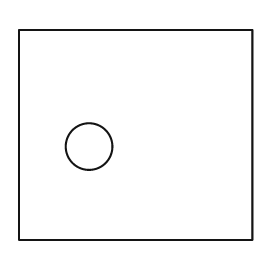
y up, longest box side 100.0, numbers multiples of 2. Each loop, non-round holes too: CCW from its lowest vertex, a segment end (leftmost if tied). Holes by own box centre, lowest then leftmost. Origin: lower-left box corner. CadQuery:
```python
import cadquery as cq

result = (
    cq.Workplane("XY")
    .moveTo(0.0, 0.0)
    .lineTo(100.0, 0.0)
    .lineTo(100.0, 90.0)
    .lineTo(0.0, 90.0)
    .close()
    .moveTo(30.0, 40.0)
    .circle(10.0)
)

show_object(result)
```